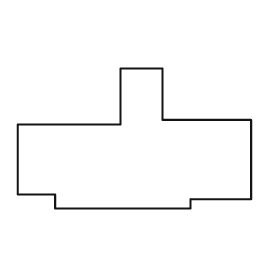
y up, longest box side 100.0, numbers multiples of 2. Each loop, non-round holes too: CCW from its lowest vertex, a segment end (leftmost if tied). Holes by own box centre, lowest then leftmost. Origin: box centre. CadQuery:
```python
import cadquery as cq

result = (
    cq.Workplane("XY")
    .moveTo(-34.0, -30.0)
    .lineTo(24.0, -30.0)
    .lineTo(24.0, -26.0)
    .lineTo(50.0, -26.0)
    .lineTo(50.0, 8.0)
    .lineTo(12.0, 8.0)
    .lineTo(12.0, 30.0)
    .lineTo(-6.0, 30.0)
    .lineTo(-6.0, 6.0)
    .lineTo(-50.0, 6.0)
    .lineTo(-50.0, -24.0)
    .lineTo(-34.0, -24.0)
    .close()
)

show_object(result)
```